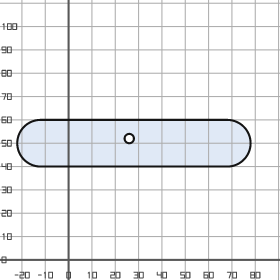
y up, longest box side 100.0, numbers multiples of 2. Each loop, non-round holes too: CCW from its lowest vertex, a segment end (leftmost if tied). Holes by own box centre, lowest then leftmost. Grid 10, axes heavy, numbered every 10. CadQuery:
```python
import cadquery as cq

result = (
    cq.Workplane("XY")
    .moveTo(-12.0, 40.0)
    .lineTo(68.0, 40.0)
    .threePointArc((78.0, 50.0), (68.0, 60.0))
    .lineTo(-12.0, 60.0)
    .threePointArc((-22.0, 50.0), (-12.0, 40.0))
    .close()
    .moveTo(26.0, 52.0)
    .circle(2.0)
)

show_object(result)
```